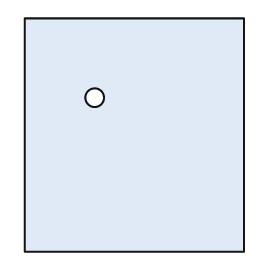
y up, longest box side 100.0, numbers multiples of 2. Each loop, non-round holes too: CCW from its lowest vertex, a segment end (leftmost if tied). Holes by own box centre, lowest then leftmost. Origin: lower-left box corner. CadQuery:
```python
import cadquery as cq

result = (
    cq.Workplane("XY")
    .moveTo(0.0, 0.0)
    .lineTo(94.0, 0.0)
    .lineTo(94.0, 100.0)
    .lineTo(0.0, 100.0)
    .close()
    .moveTo(30.0, 66.0)
    .circle(4.0)
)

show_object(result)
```